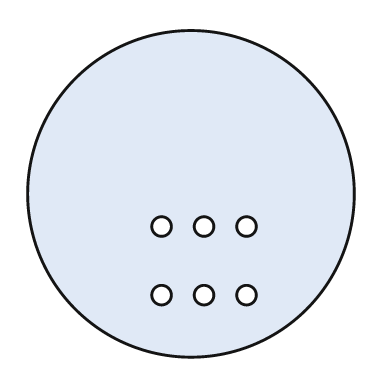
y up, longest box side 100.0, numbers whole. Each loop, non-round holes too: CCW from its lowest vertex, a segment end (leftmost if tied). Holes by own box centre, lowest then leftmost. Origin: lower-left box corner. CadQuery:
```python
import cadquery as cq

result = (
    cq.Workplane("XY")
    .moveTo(50.0, 50.0)
    .circle(50.0)
    .moveTo(41.0, 19.0)
    .circle(3.0)
    .moveTo(54.0, 19.0)
    .circle(3.0)
    .moveTo(67.0, 19.0)
    .circle(3.0)
    .moveTo(41.0, 40.0)
    .circle(3.0)
    .moveTo(54.0, 40.0)
    .circle(3.0)
    .moveTo(67.0, 40.0)
    .circle(3.0)
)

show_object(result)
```